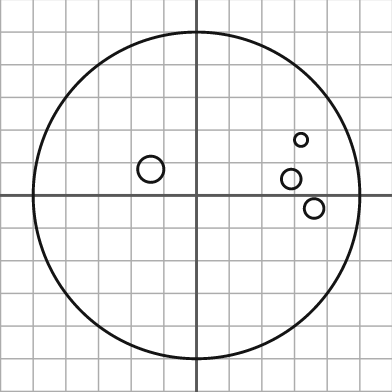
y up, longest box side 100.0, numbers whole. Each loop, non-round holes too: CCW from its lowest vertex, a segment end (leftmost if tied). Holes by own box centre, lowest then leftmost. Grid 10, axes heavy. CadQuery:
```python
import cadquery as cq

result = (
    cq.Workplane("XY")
    .moveTo(0.0, 0.0)
    .circle(50.0)
    .moveTo(36.0, -4.0)
    .circle(3.0)
    .moveTo(29.0, 5.0)
    .circle(3.0)
    .moveTo(-14.0, 8.0)
    .circle(4.0)
    .moveTo(32.0, 17.0)
    .circle(2.0)
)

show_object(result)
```